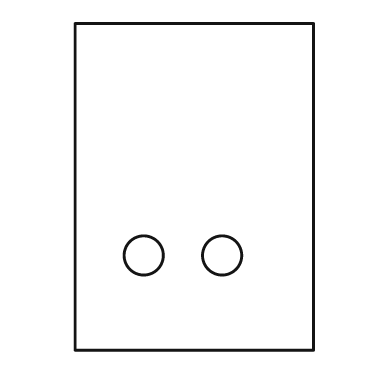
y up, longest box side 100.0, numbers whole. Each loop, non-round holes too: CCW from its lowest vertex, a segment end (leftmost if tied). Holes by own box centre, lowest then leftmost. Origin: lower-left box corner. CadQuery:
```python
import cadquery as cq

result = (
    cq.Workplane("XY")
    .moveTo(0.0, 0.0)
    .lineTo(73.0, 0.0)
    .lineTo(73.0, 100.0)
    .lineTo(0.0, 100.0)
    .close()
    .moveTo(21.0, 29.0)
    .circle(6.0)
    .moveTo(45.0, 29.0)
    .circle(6.0)
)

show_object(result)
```